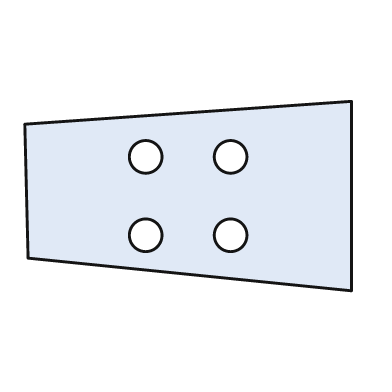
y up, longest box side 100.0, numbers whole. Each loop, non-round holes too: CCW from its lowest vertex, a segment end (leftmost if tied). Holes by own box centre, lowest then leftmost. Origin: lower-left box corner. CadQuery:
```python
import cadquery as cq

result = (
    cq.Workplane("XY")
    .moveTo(100.0, 0.0)
    .lineTo(100.0, 58.0)
    .lineTo(0.0, 51.0)
    .lineTo(1.0, 10.0)
    .close()
    .moveTo(37.0, 17.0)
    .circle(5.0)
    .moveTo(63.0, 17.0)
    .circle(5.0)
    .moveTo(37.0, 41.0)
    .circle(5.0)
    .moveTo(63.0, 41.0)
    .circle(5.0)
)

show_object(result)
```